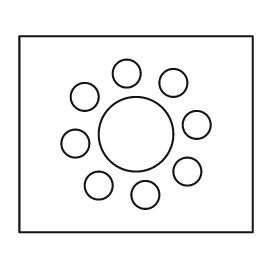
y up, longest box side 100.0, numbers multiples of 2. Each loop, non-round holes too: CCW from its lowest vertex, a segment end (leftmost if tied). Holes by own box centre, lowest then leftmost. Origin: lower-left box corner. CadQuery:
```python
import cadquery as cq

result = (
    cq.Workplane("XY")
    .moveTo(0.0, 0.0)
    .lineTo(100.0, 0.0)
    .lineTo(100.0, 84.0)
    .lineTo(0.0, 84.0)
    .close()
    .moveTo(54.0, 16.0)
    .circle(6.0)
    .moveTo(34.0, 20.0)
    .circle(6.0)
    .moveTo(72.0, 26.0)
    .circle(6.0)
    .moveTo(24.0, 38.0)
    .circle(6.0)
    .moveTo(50.0, 42.0)
    .circle(16.0)
    .moveTo(76.0, 46.0)
    .circle(6.0)
    .moveTo(28.0, 58.0)
    .circle(6.0)
    .moveTo(66.0, 64.0)
    .circle(6.0)
    .moveTo(46.0, 68.0)
    .circle(6.0)
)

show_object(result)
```